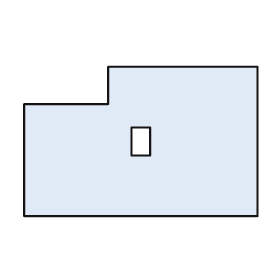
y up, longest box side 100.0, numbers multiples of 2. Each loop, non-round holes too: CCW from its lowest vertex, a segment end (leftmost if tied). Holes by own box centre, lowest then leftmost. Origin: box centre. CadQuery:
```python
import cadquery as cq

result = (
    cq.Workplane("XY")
    .moveTo(-50.0, -32.0)
    .lineTo(50.0, -32.0)
    .lineTo(50.0, 32.0)
    .lineTo(-14.0, 32.0)
    .lineTo(-14.0, 16.0)
    .lineTo(-50.0, 16.0)
    .close()
    .moveTo(-4.0, -6.0)
    .lineTo(4.0, -6.0)
    .lineTo(4.0, 6.0)
    .lineTo(-4.0, 6.0)
    .close()
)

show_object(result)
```